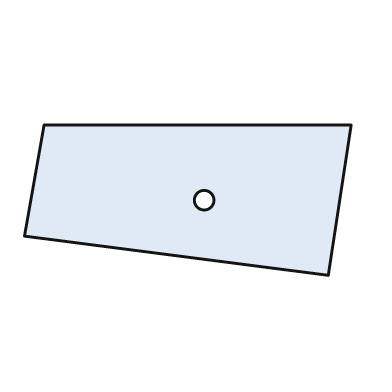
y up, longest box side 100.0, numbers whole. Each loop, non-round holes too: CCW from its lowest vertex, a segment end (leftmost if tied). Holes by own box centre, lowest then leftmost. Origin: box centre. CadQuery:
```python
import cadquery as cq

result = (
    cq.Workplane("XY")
    .moveTo(43.0, -23.0)
    .lineTo(50.0, 23.0)
    .lineTo(-44.0, 23.0)
    .lineTo(-50.0, -11.0)
    .close()
    .moveTo(5.0, 0.0)
    .circle(3.0)
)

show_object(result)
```